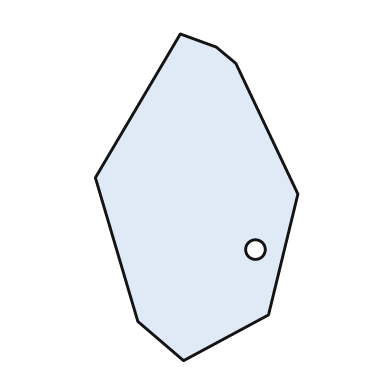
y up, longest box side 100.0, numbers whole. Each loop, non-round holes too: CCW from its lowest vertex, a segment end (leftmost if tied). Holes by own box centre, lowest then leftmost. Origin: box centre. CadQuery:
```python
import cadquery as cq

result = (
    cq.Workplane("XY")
    .moveTo(-4.0, -50.0)
    .lineTo(22.0, -36.0)
    .lineTo(31.0, 1.0)
    .lineTo(12.0, 41.0)
    .lineTo(6.0, 46.0)
    .lineTo(-5.0, 50.0)
    .lineTo(-31.0, 6.0)
    .lineTo(-18.0, -38.0)
    .close()
    .moveTo(18.0, -16.0)
    .circle(3.0)
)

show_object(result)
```